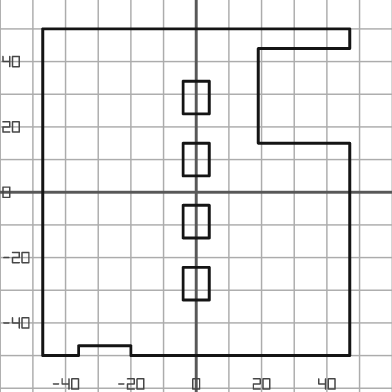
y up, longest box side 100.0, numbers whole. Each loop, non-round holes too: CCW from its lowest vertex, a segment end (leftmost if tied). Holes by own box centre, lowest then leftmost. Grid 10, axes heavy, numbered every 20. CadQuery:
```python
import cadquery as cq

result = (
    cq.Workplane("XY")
    .moveTo(-47.0, -50.0)
    .lineTo(-36.0, -50.0)
    .lineTo(-36.0, -47.0)
    .lineTo(-20.0, -47.0)
    .lineTo(-20.0, -50.0)
    .lineTo(47.0, -50.0)
    .lineTo(47.0, 15.0)
    .lineTo(19.0, 15.0)
    .lineTo(19.0, 44.0)
    .lineTo(47.0, 44.0)
    .lineTo(47.0, 50.0)
    .lineTo(-47.0, 50.0)
    .close()
    .moveTo(-4.0, -33.0)
    .lineTo(4.0, -33.0)
    .lineTo(4.0, -23.0)
    .lineTo(-4.0, -23.0)
    .close()
    .moveTo(-4.0, -14.0)
    .lineTo(4.0, -14.0)
    .lineTo(4.0, -4.0)
    .lineTo(-4.0, -4.0)
    .close()
    .moveTo(-4.0, 5.0)
    .lineTo(4.0, 5.0)
    .lineTo(4.0, 15.0)
    .lineTo(-4.0, 15.0)
    .close()
    .moveTo(-4.0, 24.0)
    .lineTo(4.0, 24.0)
    .lineTo(4.0, 34.0)
    .lineTo(-4.0, 34.0)
    .close()
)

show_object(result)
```